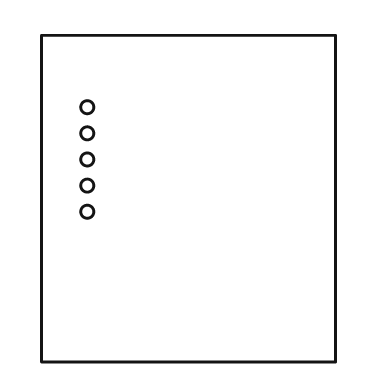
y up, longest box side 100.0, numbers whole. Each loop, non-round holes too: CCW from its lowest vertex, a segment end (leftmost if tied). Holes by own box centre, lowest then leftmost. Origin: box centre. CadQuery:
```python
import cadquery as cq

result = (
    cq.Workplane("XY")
    .moveTo(-45.0, -50.0)
    .lineTo(45.0, -50.0)
    .lineTo(45.0, 50.0)
    .lineTo(-45.0, 50.0)
    .close()
    .moveTo(-31.0, -4.0)
    .circle(2.0)
    .moveTo(-31.0, 4.0)
    .circle(2.0)
    .moveTo(-31.0, 12.0)
    .circle(2.0)
    .moveTo(-31.0, 20.0)
    .circle(2.0)
    .moveTo(-31.0, 28.0)
    .circle(2.0)
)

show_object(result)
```